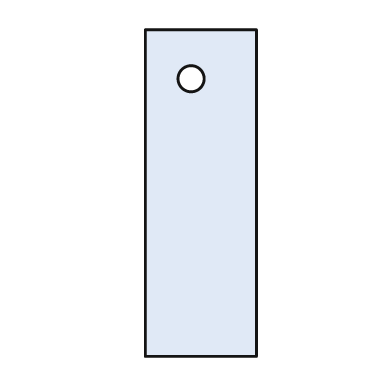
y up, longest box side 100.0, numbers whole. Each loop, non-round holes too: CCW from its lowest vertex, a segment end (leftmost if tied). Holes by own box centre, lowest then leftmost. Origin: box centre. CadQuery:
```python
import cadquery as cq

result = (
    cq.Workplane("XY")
    .moveTo(-17.0, -50.0)
    .lineTo(17.0, -50.0)
    .lineTo(17.0, 50.0)
    .lineTo(-17.0, 50.0)
    .close()
    .moveTo(-3.0, 35.0)
    .circle(4.0)
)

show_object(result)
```